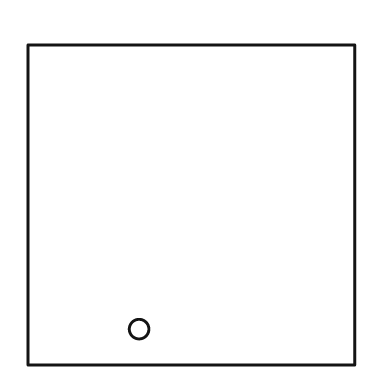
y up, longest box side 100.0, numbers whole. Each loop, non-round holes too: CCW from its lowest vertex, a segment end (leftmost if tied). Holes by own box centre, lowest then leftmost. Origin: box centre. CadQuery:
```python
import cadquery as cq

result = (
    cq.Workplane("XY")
    .moveTo(-50.0, -49.0)
    .lineTo(50.0, -49.0)
    .lineTo(50.0, 49.0)
    .lineTo(-50.0, 49.0)
    .close()
    .moveTo(-16.0, -38.0)
    .circle(3.0)
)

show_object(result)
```